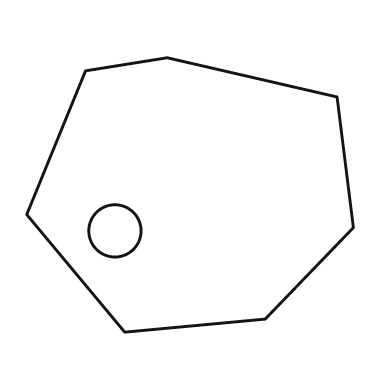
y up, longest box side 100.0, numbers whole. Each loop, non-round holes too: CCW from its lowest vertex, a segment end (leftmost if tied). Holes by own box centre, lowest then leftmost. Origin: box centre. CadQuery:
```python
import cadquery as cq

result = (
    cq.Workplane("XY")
    .moveTo(-20.0, -42.0)
    .lineTo(23.0, -38.0)
    .lineTo(50.0, -10.0)
    .lineTo(45.0, 30.0)
    .lineTo(-7.0, 42.0)
    .lineTo(-32.0, 38.0)
    .lineTo(-50.0, -6.0)
    .close()
    .moveTo(-23.0, -11.0)
    .circle(8.0)
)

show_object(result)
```